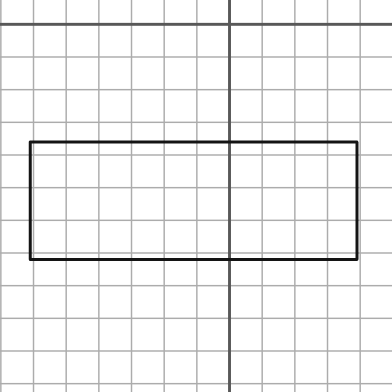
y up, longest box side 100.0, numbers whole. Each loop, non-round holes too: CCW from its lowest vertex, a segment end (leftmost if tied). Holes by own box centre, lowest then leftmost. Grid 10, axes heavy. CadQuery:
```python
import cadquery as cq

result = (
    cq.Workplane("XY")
    .moveTo(-61.0, -72.0)
    .lineTo(39.0, -72.0)
    .lineTo(39.0, -36.0)
    .lineTo(-61.0, -36.0)
    .close()
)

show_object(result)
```